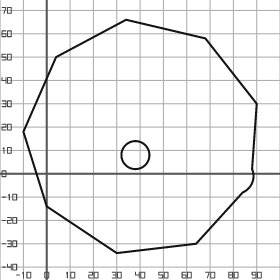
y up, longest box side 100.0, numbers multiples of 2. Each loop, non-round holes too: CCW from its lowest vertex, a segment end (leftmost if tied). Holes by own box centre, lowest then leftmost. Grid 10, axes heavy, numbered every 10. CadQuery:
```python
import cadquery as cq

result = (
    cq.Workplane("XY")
    .moveTo(30.0, -34.0)
    .lineTo(64.0, -30.0)
    .lineTo(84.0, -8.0)
    .threePointArc((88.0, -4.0), (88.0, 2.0))
    .lineTo(90.0, 30.0)
    .lineTo(68.0, 58.0)
    .lineTo(34.0, 66.0)
    .lineTo(4.0, 50.0)
    .lineTo(-10.0, 18.0)
    .lineTo(0.0, -14.0)
    .close()
    .moveTo(38.0, 8.0)
    .circle(6.0)
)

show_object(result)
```